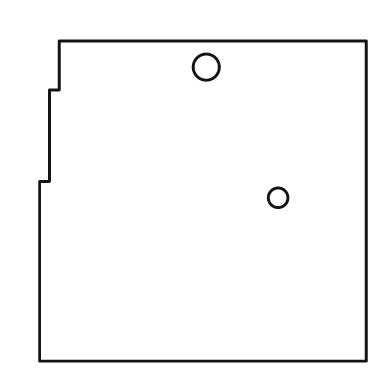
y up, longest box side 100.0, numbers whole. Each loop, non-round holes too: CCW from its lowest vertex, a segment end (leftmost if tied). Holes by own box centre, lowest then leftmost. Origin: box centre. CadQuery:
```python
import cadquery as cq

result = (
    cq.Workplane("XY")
    .moveTo(-50.0, -49.0)
    .lineTo(50.0, -49.0)
    .lineTo(50.0, 49.0)
    .lineTo(-44.0, 49.0)
    .lineTo(-44.0, 34.0)
    .lineTo(-47.0, 34.0)
    .lineTo(-47.0, 6.0)
    .lineTo(-50.0, 6.0)
    .close()
    .moveTo(23.0, 1.0)
    .circle(3.0)
    .moveTo(1.0, 41.0)
    .circle(4.0)
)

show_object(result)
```